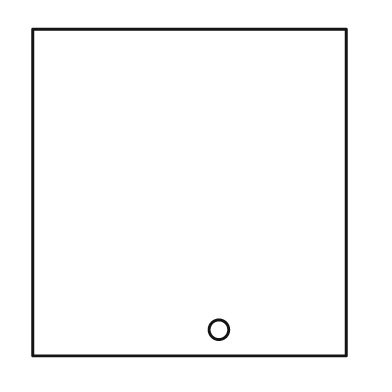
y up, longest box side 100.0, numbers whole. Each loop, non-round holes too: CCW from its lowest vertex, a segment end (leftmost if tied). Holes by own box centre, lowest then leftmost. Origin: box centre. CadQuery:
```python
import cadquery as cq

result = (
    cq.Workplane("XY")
    .moveTo(-48.0, -50.0)
    .lineTo(48.0, -50.0)
    .lineTo(48.0, 50.0)
    .lineTo(-48.0, 50.0)
    .close()
    .moveTo(9.0, -42.0)
    .circle(3.0)
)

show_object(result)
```